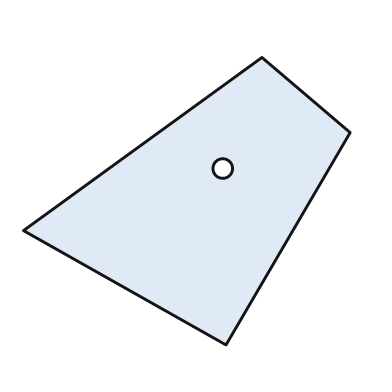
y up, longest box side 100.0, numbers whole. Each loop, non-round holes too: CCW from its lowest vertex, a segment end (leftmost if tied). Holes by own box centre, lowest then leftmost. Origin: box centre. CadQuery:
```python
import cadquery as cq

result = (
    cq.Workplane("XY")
    .moveTo(12.0, -44.0)
    .lineTo(50.0, 21.0)
    .lineTo(23.0, 44.0)
    .lineTo(-50.0, -9.0)
    .close()
    .moveTo(11.0, 10.0)
    .circle(3.0)
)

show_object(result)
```